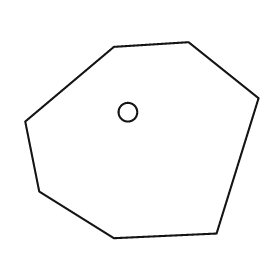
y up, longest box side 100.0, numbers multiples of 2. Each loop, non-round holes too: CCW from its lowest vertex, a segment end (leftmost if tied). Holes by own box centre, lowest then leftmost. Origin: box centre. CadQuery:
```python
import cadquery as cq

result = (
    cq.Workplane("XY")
    .moveTo(-12.0, -42.0)
    .lineTo(32.0, -40.0)
    .lineTo(50.0, 18.0)
    .lineTo(20.0, 42.0)
    .lineTo(-12.0, 40.0)
    .lineTo(-50.0, 8.0)
    .lineTo(-44.0, -22.0)
    .close()
    .moveTo(-6.0, 12.0)
    .circle(4.0)
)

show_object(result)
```